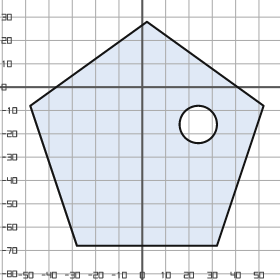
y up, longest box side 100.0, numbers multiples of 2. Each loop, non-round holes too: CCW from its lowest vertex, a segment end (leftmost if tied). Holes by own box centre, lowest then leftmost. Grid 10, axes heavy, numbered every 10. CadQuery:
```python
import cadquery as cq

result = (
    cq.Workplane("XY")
    .moveTo(-28.0, -68.0)
    .lineTo(32.0, -68.0)
    .lineTo(52.0, -8.0)
    .lineTo(2.0, 28.0)
    .lineTo(-48.0, -8.0)
    .close()
    .moveTo(24.0, -16.0)
    .circle(8.0)
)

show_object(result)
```